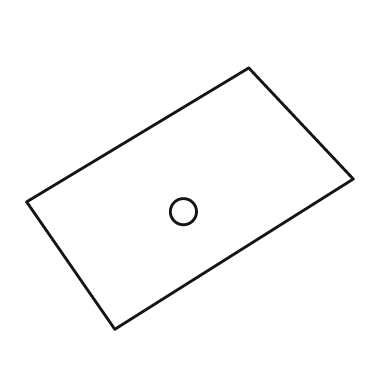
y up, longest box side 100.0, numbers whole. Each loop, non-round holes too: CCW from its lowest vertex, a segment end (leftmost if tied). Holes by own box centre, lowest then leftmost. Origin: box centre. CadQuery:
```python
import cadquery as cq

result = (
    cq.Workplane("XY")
    .moveTo(-23.0, -40.0)
    .lineTo(50.0, 6.0)
    .lineTo(18.0, 40.0)
    .lineTo(-50.0, -1.0)
    .close()
    .moveTo(-2.0, -4.0)
    .circle(4.0)
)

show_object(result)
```